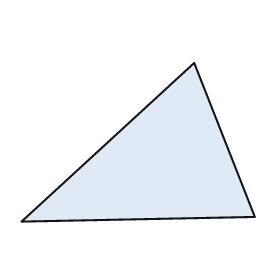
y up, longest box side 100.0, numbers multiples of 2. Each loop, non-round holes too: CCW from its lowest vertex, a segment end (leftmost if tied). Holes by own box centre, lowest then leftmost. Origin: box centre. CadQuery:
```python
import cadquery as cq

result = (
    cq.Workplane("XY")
    .moveTo(-50.0, -34.0)
    .lineTo(50.0, -32.0)
    .lineTo(24.0, 34.0)
    .close()
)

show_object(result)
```